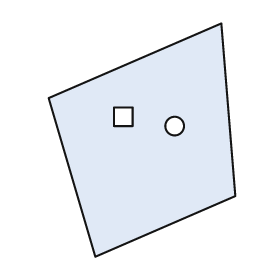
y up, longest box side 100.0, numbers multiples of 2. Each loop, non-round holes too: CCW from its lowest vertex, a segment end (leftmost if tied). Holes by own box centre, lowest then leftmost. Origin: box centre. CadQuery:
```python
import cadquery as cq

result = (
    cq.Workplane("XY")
    .moveTo(-20.0, -50.0)
    .lineTo(40.0, -24.0)
    .lineTo(34.0, 50.0)
    .lineTo(-40.0, 18.0)
    .close()
    .moveTo(14.0, 6.0)
    .circle(4.0)
    .moveTo(-12.0, 6.0)
    .lineTo(-4.0, 6.0)
    .lineTo(-4.0, 14.0)
    .lineTo(-12.0, 14.0)
    .close()
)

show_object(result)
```